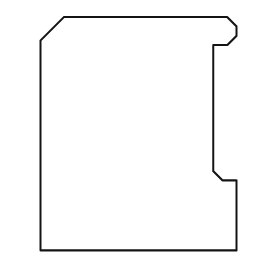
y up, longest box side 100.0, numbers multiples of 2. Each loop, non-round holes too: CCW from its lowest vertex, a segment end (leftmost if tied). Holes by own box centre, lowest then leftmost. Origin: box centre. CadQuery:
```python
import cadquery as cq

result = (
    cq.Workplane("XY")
    .moveTo(-42.0, -50.0)
    .lineTo(42.0, -50.0)
    .lineTo(42.0, -20.0)
    .lineTo(36.0, -20.0)
    .lineTo(32.0, -16.0)
    .lineTo(32.0, 38.0)
    .lineTo(38.0, 38.0)
    .lineTo(42.0, 42.0)
    .lineTo(42.0, 46.0)
    .lineTo(38.0, 50.0)
    .lineTo(-32.0, 50.0)
    .lineTo(-42.0, 40.0)
    .close()
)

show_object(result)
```